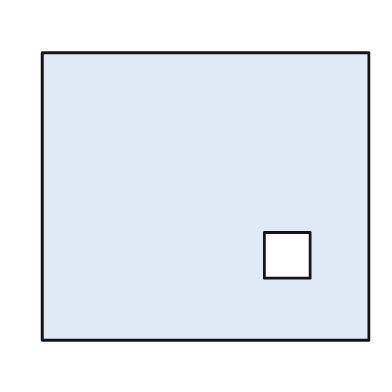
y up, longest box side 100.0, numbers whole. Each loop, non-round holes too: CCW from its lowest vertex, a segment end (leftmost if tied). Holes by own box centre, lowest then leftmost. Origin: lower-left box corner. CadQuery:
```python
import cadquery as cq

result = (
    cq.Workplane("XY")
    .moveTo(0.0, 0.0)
    .lineTo(100.0, 0.0)
    .lineTo(100.0, 88.0)
    .lineTo(0.0, 88.0)
    .close()
    .moveTo(68.0, 19.0)
    .lineTo(82.0, 19.0)
    .lineTo(82.0, 33.0)
    .lineTo(68.0, 33.0)
    .close()
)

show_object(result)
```